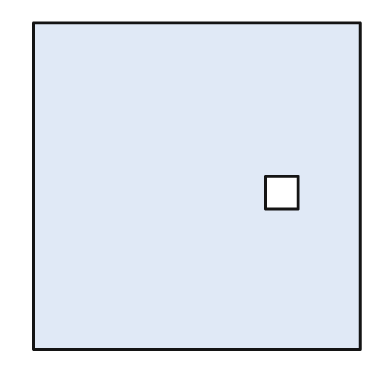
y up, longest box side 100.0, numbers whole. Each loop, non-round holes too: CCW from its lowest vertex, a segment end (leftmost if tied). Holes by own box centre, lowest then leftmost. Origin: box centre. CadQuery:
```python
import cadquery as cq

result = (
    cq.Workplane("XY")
    .moveTo(-50.0, -50.0)
    .lineTo(50.0, -50.0)
    .lineTo(50.0, 50.0)
    .lineTo(-50.0, 50.0)
    .close()
    .moveTo(21.0, -7.0)
    .lineTo(31.0, -7.0)
    .lineTo(31.0, 3.0)
    .lineTo(21.0, 3.0)
    .close()
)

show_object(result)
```